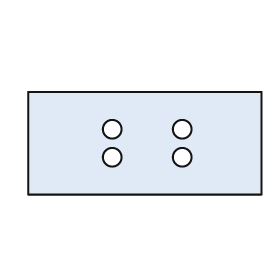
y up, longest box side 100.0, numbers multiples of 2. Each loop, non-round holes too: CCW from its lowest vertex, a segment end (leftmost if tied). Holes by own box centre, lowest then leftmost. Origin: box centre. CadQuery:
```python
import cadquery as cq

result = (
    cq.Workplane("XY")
    .moveTo(-50.0, -22.0)
    .lineTo(50.0, -22.0)
    .lineTo(50.0, 22.0)
    .lineTo(-50.0, 22.0)
    .close()
    .moveTo(-14.0, -6.0)
    .circle(4.0)
    .moveTo(16.0, -6.0)
    .circle(4.0)
    .moveTo(-14.0, 6.0)
    .circle(4.0)
    .moveTo(16.0, 6.0)
    .circle(4.0)
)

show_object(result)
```